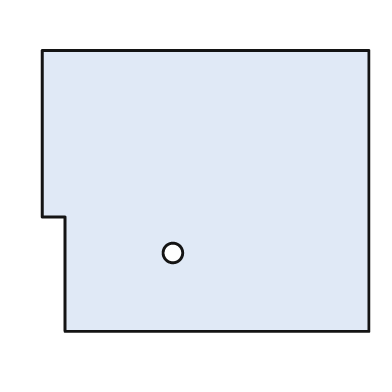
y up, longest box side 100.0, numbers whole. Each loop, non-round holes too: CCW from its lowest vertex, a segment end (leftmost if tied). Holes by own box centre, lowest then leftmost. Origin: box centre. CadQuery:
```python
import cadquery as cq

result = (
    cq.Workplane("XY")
    .moveTo(-43.0, -43.0)
    .lineTo(50.0, -43.0)
    .lineTo(50.0, 43.0)
    .lineTo(-50.0, 43.0)
    .lineTo(-50.0, -8.0)
    .lineTo(-43.0, -8.0)
    .close()
    .moveTo(-10.0, -19.0)
    .circle(3.0)
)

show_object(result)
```